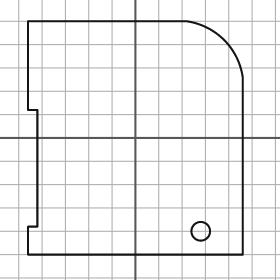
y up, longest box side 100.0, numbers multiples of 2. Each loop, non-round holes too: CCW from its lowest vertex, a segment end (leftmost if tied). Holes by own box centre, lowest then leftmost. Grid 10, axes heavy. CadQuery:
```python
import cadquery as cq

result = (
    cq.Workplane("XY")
    .moveTo(-46.0, -50.0)
    .lineTo(46.0, -50.0)
    .lineTo(46.0, 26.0)
    .threePointArc((38.0, 42.0), (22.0, 50.0))
    .lineTo(-46.0, 50.0)
    .lineTo(-46.0, 12.0)
    .lineTo(-42.0, 12.0)
    .lineTo(-42.0, -38.0)
    .lineTo(-46.0, -38.0)
    .close()
    .moveTo(28.0, -40.0)
    .circle(4.0)
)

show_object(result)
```